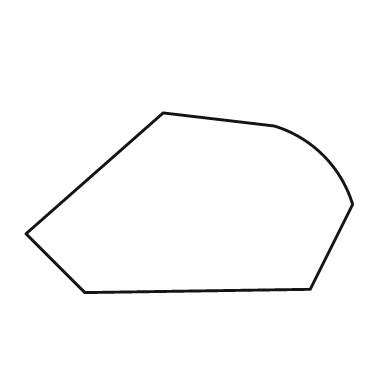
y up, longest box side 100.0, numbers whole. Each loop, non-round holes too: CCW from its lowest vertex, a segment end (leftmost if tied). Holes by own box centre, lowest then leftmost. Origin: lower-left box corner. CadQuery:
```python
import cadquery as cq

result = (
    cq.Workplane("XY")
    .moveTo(18.0, 0.0)
    .lineTo(87.0, 1.0)
    .lineTo(100.0, 27.0)
    .threePointArc((91.0, 42.0), (76.0, 51.0))
    .lineTo(42.0, 55.0)
    .lineTo(0.0, 18.0)
    .close()
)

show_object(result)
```